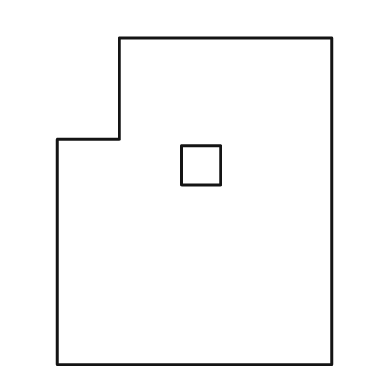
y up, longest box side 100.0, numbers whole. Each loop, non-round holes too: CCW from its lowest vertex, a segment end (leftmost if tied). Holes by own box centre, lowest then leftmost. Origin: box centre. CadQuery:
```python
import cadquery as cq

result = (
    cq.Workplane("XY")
    .moveTo(-42.0, -50.0)
    .lineTo(42.0, -50.0)
    .lineTo(42.0, 50.0)
    .lineTo(-23.0, 50.0)
    .lineTo(-23.0, 19.0)
    .lineTo(-42.0, 19.0)
    .close()
    .moveTo(-4.0, 5.0)
    .lineTo(8.0, 5.0)
    .lineTo(8.0, 17.0)
    .lineTo(-4.0, 17.0)
    .close()
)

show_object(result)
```